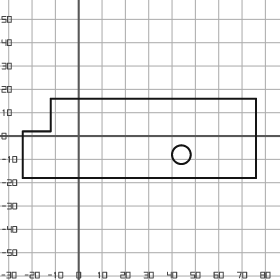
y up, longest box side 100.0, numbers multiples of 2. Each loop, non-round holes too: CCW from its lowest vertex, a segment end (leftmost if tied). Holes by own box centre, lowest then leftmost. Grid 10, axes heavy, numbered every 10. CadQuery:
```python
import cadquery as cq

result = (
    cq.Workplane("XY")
    .moveTo(-24.0, -18.0)
    .lineTo(76.0, -18.0)
    .lineTo(76.0, 16.0)
    .lineTo(-12.0, 16.0)
    .lineTo(-12.0, 2.0)
    .lineTo(-24.0, 2.0)
    .close()
    .moveTo(44.0, -8.0)
    .circle(4.0)
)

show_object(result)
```